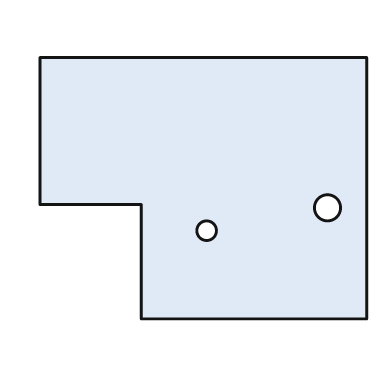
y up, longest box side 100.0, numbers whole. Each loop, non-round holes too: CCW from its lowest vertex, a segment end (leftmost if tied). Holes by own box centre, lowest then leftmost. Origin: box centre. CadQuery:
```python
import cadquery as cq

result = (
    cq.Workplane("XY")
    .moveTo(-19.0, -40.0)
    .lineTo(50.0, -40.0)
    .lineTo(50.0, 40.0)
    .lineTo(-50.0, 40.0)
    .lineTo(-50.0, -5.0)
    .lineTo(-19.0, -5.0)
    .close()
    .moveTo(1.0, -13.0)
    .circle(3.0)
    .moveTo(38.0, -6.0)
    .circle(4.0)
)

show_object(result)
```